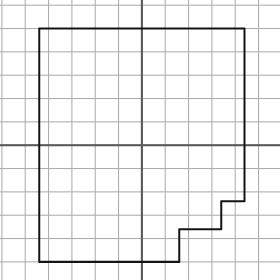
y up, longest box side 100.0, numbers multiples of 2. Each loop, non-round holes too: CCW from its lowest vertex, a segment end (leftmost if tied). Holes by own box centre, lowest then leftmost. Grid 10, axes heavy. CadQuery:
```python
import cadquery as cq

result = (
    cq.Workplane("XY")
    .moveTo(-44.0, -50.0)
    .lineTo(16.0, -50.0)
    .lineTo(16.0, -36.0)
    .lineTo(34.0, -36.0)
    .lineTo(34.0, -24.0)
    .lineTo(44.0, -24.0)
    .lineTo(44.0, 50.0)
    .lineTo(-44.0, 50.0)
    .close()
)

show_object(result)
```